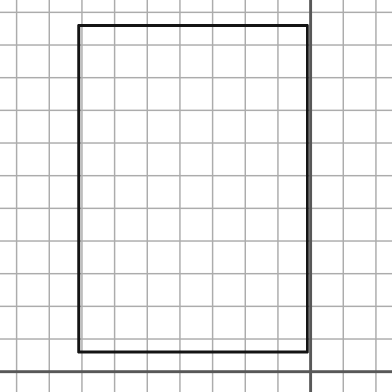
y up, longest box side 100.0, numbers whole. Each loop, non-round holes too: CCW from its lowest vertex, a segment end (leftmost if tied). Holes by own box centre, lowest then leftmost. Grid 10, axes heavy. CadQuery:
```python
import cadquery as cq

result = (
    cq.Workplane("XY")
    .moveTo(-71.0, 6.0)
    .lineTo(-1.0, 6.0)
    .lineTo(-1.0, 106.0)
    .lineTo(-71.0, 106.0)
    .close()
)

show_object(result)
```